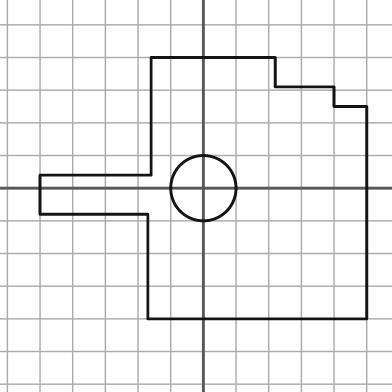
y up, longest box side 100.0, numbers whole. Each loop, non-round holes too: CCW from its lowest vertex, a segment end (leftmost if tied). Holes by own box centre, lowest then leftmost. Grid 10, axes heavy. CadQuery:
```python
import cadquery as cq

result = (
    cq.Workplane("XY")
    .moveTo(-17.0, -40.0)
    .lineTo(50.0, -40.0)
    .lineTo(50.0, 25.0)
    .lineTo(40.0, 25.0)
    .lineTo(40.0, 31.0)
    .lineTo(22.0, 31.0)
    .lineTo(22.0, 40.0)
    .lineTo(-16.0, 40.0)
    .lineTo(-16.0, 4.0)
    .lineTo(-50.0, 4.0)
    .lineTo(-50.0, -8.0)
    .lineTo(-17.0, -8.0)
    .close()
    .moveTo(0.0, 0.0)
    .circle(10.0)
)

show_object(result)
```